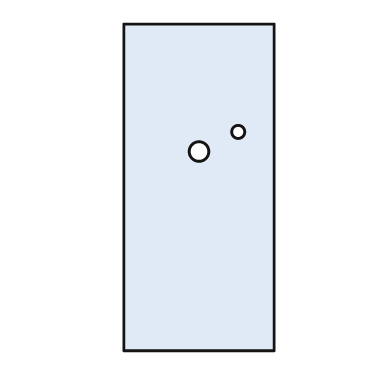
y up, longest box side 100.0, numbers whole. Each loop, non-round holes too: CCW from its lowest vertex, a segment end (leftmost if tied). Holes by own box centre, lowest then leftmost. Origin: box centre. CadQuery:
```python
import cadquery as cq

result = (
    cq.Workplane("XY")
    .moveTo(-23.0, -50.0)
    .lineTo(23.0, -50.0)
    .lineTo(23.0, 50.0)
    .lineTo(-23.0, 50.0)
    .close()
    .moveTo(0.0, 11.0)
    .circle(3.0)
    .moveTo(12.0, 17.0)
    .circle(2.0)
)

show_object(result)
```